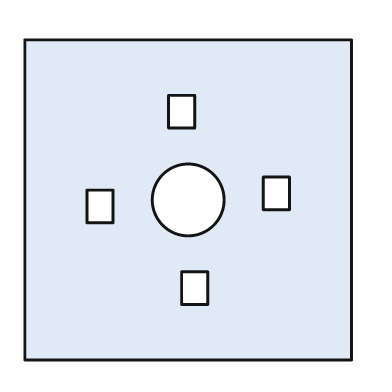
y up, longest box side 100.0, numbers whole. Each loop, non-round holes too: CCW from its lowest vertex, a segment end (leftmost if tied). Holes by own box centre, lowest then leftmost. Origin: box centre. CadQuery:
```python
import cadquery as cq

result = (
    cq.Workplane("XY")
    .moveTo(-50.0, -49.0)
    .lineTo(50.0, -49.0)
    .lineTo(50.0, 49.0)
    .lineTo(-50.0, 49.0)
    .close()
    .moveTo(-2.0, -32.0)
    .lineTo(6.0, -32.0)
    .lineTo(6.0, -22.0)
    .lineTo(-2.0, -22.0)
    .close()
    .moveTo(-31.0, -7.0)
    .lineTo(-23.0, -7.0)
    .lineTo(-23.0, 3.0)
    .lineTo(-31.0, 3.0)
    .close()
    .moveTo(0.0, 0.0)
    .circle(11.0)
    .moveTo(23.0, -3.0)
    .lineTo(31.0, -3.0)
    .lineTo(31.0, 7.0)
    .lineTo(23.0, 7.0)
    .close()
    .moveTo(-6.0, 22.0)
    .lineTo(2.0, 22.0)
    .lineTo(2.0, 32.0)
    .lineTo(-6.0, 32.0)
    .close()
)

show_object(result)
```